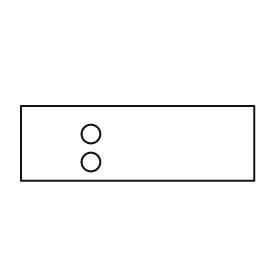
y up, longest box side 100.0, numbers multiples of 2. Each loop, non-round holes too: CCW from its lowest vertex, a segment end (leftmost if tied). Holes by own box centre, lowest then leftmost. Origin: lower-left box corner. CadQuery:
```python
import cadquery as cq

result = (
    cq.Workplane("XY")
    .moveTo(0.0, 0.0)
    .lineTo(100.0, 0.0)
    .lineTo(100.0, 32.0)
    .lineTo(0.0, 32.0)
    .close()
    .moveTo(30.0, 8.0)
    .circle(4.0)
    .moveTo(30.0, 20.0)
    .circle(4.0)
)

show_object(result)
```